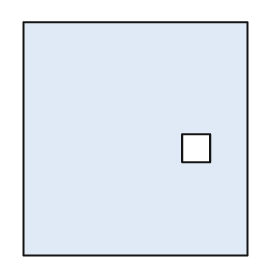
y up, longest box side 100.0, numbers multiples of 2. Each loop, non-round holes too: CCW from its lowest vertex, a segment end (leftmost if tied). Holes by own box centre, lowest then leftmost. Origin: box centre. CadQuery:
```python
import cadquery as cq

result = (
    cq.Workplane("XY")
    .moveTo(-48.0, -50.0)
    .lineTo(48.0, -50.0)
    .lineTo(48.0, 50.0)
    .lineTo(-48.0, 50.0)
    .close()
    .moveTo(20.0, -10.0)
    .lineTo(32.0, -10.0)
    .lineTo(32.0, 2.0)
    .lineTo(20.0, 2.0)
    .close()
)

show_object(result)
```